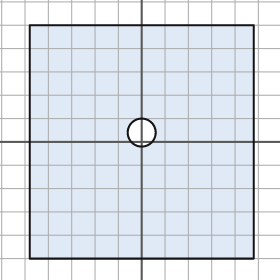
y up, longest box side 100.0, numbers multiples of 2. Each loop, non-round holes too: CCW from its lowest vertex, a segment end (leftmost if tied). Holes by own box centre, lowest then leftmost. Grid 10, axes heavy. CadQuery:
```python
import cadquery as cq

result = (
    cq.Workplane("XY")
    .moveTo(-48.0, -50.0)
    .lineTo(48.0, -50.0)
    .lineTo(48.0, 50.0)
    .lineTo(-48.0, 50.0)
    .close()
    .moveTo(0.0, 4.0)
    .circle(6.0)
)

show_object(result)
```